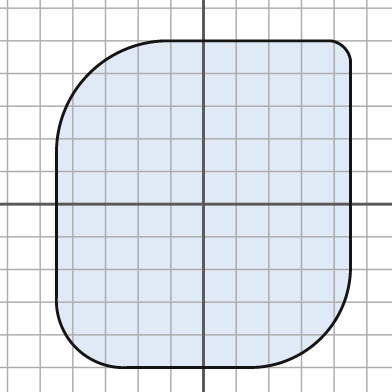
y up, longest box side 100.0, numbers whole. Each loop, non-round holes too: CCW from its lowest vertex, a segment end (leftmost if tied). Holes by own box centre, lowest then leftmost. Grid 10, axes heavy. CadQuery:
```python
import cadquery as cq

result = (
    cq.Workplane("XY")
    .moveTo(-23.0, -50.0)
    .lineTo(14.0, -50.0)
    .threePointArc((36.0, -41.0), (45.0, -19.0))
    .lineTo(45.0, 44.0)
    .threePointArc((43.0, 48.0), (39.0, 50.0))
    .lineTo(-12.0, 50.0)
    .threePointArc((-35.0, 40.0), (-45.0, 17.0))
    .lineTo(-45.0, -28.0)
    .threePointArc((-39.0, -44.0), (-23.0, -50.0))
    .close()
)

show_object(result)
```